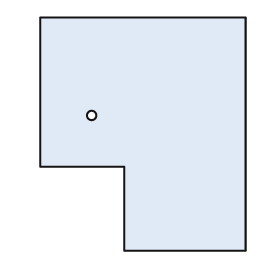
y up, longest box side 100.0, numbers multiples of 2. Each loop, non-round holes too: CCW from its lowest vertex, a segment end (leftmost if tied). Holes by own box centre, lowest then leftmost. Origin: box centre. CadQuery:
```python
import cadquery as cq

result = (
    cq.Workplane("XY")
    .moveTo(-8.0, -50.0)
    .lineTo(44.0, -50.0)
    .lineTo(44.0, 50.0)
    .lineTo(-44.0, 50.0)
    .lineTo(-44.0, -14.0)
    .lineTo(-8.0, -14.0)
    .close()
    .moveTo(-22.0, 8.0)
    .circle(2.0)
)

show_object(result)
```